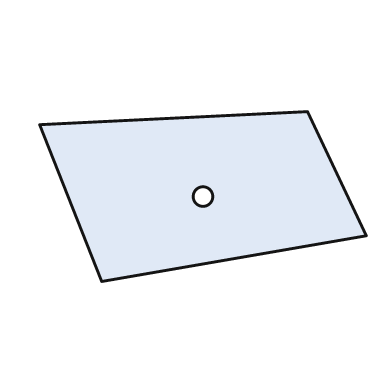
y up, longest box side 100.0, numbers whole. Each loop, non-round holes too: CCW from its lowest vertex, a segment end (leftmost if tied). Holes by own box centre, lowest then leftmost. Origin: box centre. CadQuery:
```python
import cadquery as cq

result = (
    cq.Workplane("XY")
    .moveTo(-31.0, -26.0)
    .lineTo(50.0, -12.0)
    .lineTo(32.0, 26.0)
    .lineTo(-50.0, 22.0)
    .close()
    .moveTo(0.0, 0.0)
    .circle(3.0)
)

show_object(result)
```